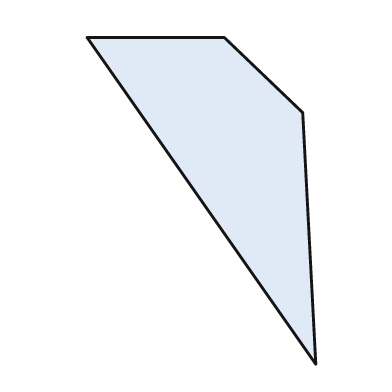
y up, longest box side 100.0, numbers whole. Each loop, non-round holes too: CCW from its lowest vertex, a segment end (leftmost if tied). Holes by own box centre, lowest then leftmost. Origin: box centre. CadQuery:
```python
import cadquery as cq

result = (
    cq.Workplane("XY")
    .moveTo(35.0, -50.0)
    .lineTo(31.0, 27.0)
    .lineTo(7.0, 50.0)
    .lineTo(-35.0, 50.0)
    .close()
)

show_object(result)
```